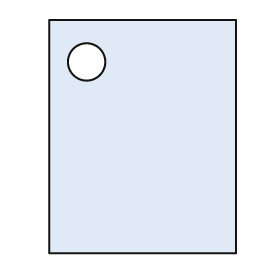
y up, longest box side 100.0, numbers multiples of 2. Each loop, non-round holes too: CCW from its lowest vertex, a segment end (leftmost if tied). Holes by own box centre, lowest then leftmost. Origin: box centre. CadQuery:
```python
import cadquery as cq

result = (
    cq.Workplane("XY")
    .moveTo(-40.0, -50.0)
    .lineTo(40.0, -50.0)
    .lineTo(40.0, 50.0)
    .lineTo(-40.0, 50.0)
    .close()
    .moveTo(-24.0, 32.0)
    .circle(8.0)
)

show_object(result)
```